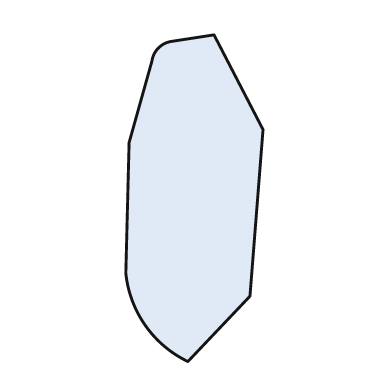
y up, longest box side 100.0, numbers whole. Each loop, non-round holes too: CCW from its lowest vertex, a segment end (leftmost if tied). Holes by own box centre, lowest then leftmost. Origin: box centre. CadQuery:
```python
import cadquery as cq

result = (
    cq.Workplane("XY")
    .moveTo(-2.0, -50.0)
    .lineTo(17.0, -30.0)
    .lineTo(21.0, 21.0)
    .lineTo(6.0, 50.0)
    .lineTo(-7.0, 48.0)
    .threePointArc((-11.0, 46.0), (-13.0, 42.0))
    .lineTo(-20.0, 17.0)
    .lineTo(-21.0, -23.0)
    .threePointArc((-15.0, -39.0), (-2.0, -50.0))
    .close()
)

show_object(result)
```